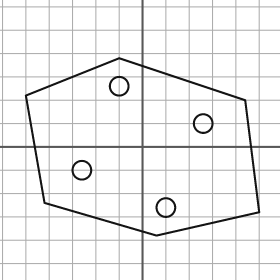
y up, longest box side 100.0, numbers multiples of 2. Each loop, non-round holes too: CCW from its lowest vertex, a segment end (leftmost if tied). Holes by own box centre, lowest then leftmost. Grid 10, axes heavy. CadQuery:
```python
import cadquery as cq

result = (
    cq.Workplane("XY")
    .moveTo(6.0, -38.0)
    .lineTo(50.0, -28.0)
    .lineTo(44.0, 20.0)
    .lineTo(-10.0, 38.0)
    .lineTo(-50.0, 22.0)
    .lineTo(-42.0, -24.0)
    .close()
    .moveTo(10.0, -26.0)
    .circle(4.0)
    .moveTo(-26.0, -10.0)
    .circle(4.0)
    .moveTo(26.0, 10.0)
    .circle(4.0)
    .moveTo(-10.0, 26.0)
    .circle(4.0)
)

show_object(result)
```